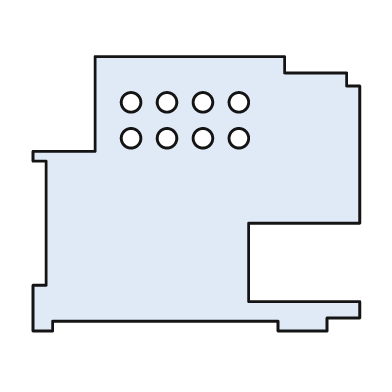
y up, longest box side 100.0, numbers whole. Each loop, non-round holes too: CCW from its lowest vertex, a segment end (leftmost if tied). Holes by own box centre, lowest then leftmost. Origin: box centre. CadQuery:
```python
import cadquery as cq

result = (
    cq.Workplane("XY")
    .moveTo(-50.0, -42.0)
    .lineTo(-44.0, -42.0)
    .lineTo(-44.0, -39.0)
    .lineTo(25.0, -39.0)
    .lineTo(25.0, -42.0)
    .lineTo(40.0, -42.0)
    .lineTo(40.0, -38.0)
    .lineTo(50.0, -38.0)
    .lineTo(50.0, -33.0)
    .lineTo(16.0, -33.0)
    .lineTo(16.0, -9.0)
    .lineTo(50.0, -9.0)
    .lineTo(50.0, 33.0)
    .lineTo(46.0, 33.0)
    .lineTo(46.0, 37.0)
    .lineTo(27.0, 37.0)
    .lineTo(27.0, 42.0)
    .lineTo(-31.0, 42.0)
    .lineTo(-31.0, 13.0)
    .lineTo(-50.0, 13.0)
    .lineTo(-50.0, 10.0)
    .lineTo(-46.0, 10.0)
    .lineTo(-46.0, -28.0)
    .lineTo(-50.0, -28.0)
    .close()
    .moveTo(-20.0, 17.0)
    .circle(3.0)
    .moveTo(-9.0, 17.0)
    .circle(3.0)
    .moveTo(2.0, 17.0)
    .circle(3.0)
    .moveTo(13.0, 17.0)
    .circle(3.0)
    .moveTo(-20.0, 28.0)
    .circle(3.0)
    .moveTo(-9.0, 28.0)
    .circle(3.0)
    .moveTo(2.0, 28.0)
    .circle(3.0)
    .moveTo(13.0, 28.0)
    .circle(3.0)
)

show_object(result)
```